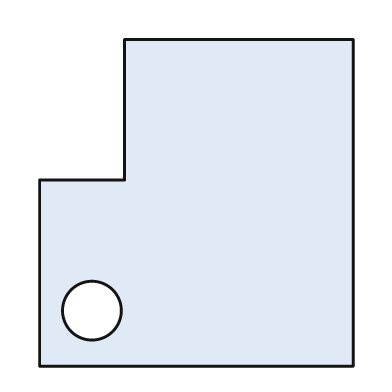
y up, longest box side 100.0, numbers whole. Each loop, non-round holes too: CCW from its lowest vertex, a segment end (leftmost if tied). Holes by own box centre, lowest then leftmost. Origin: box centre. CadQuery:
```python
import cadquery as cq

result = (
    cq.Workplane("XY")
    .moveTo(-48.0, -50.0)
    .lineTo(48.0, -50.0)
    .lineTo(48.0, 50.0)
    .lineTo(-22.0, 50.0)
    .lineTo(-22.0, 7.0)
    .lineTo(-48.0, 7.0)
    .close()
    .moveTo(-32.0, -33.0)
    .circle(9.0)
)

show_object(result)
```